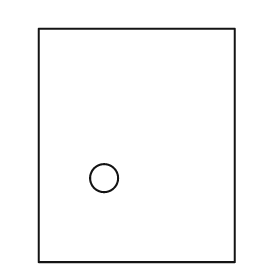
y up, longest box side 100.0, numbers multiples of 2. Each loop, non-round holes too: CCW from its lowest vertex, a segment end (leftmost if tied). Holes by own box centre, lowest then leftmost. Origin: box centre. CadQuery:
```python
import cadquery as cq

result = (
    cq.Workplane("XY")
    .moveTo(-42.0, -50.0)
    .lineTo(42.0, -50.0)
    .lineTo(42.0, 50.0)
    .lineTo(-42.0, 50.0)
    .close()
    .moveTo(-14.0, -14.0)
    .circle(6.0)
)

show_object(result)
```